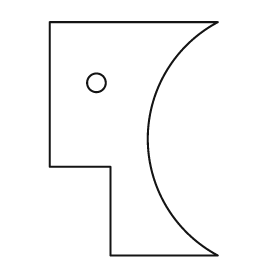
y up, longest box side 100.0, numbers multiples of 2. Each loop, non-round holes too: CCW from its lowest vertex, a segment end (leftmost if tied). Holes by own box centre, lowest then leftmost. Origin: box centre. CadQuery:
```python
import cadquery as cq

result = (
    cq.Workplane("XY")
    .moveTo(-10.0, -50.0)
    .lineTo(36.0, -50.0)
    .threePointArc((6.0, 0.0), (36.0, 50.0))
    .lineTo(-36.0, 50.0)
    .lineTo(-36.0, -12.0)
    .lineTo(-10.0, -12.0)
    .close()
    .moveTo(-16.0, 24.0)
    .circle(4.0)
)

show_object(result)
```